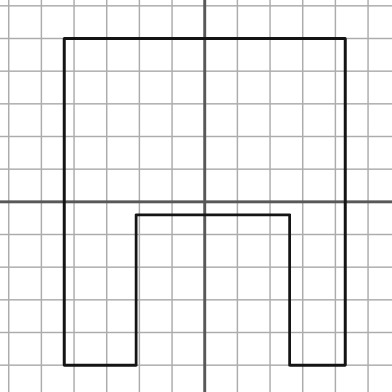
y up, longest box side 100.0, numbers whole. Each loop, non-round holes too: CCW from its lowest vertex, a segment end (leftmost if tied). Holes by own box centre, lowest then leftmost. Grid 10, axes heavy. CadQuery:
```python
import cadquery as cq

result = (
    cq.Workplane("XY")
    .moveTo(-43.0, -50.0)
    .lineTo(-21.0, -50.0)
    .lineTo(-21.0, -4.0)
    .lineTo(26.0, -4.0)
    .lineTo(26.0, -50.0)
    .lineTo(43.0, -50.0)
    .lineTo(43.0, 50.0)
    .lineTo(-43.0, 50.0)
    .close()
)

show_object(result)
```